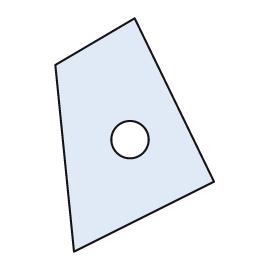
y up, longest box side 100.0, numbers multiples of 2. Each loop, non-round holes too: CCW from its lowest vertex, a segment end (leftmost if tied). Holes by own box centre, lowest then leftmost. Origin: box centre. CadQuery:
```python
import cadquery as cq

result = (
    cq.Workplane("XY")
    .moveTo(-26.0, -50.0)
    .lineTo(34.0, -20.0)
    .lineTo(0.0, 50.0)
    .lineTo(-34.0, 30.0)
    .close()
    .moveTo(-2.0, -2.0)
    .circle(8.0)
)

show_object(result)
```